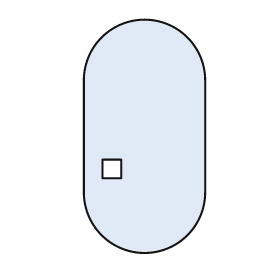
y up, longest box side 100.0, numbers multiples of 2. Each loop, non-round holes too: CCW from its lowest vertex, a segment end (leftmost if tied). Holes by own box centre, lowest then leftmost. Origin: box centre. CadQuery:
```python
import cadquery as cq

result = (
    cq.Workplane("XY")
    .moveTo(-26.0, -24.0)
    .threePointArc((0.0, -50.0), (26.0, -24.0))
    .lineTo(26.0, 24.0)
    .threePointArc((0.0, 50.0), (-26.0, 24.0))
    .close()
    .moveTo(-18.0, -18.0)
    .lineTo(-10.0, -18.0)
    .lineTo(-10.0, -10.0)
    .lineTo(-18.0, -10.0)
    .close()
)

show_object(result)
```